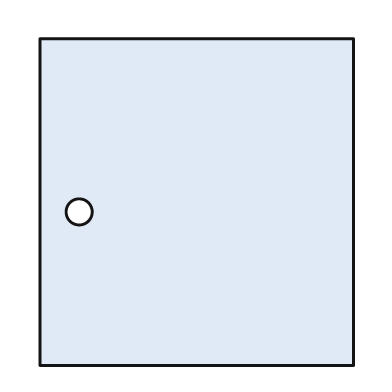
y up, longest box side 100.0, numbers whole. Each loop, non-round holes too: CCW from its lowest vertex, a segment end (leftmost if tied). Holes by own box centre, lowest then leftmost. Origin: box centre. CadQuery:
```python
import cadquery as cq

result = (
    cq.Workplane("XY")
    .moveTo(-48.0, -50.0)
    .lineTo(48.0, -50.0)
    .lineTo(48.0, 50.0)
    .lineTo(-48.0, 50.0)
    .close()
    .moveTo(-36.0, -3.0)
    .circle(4.0)
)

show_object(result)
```